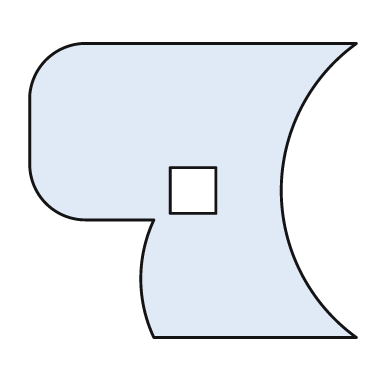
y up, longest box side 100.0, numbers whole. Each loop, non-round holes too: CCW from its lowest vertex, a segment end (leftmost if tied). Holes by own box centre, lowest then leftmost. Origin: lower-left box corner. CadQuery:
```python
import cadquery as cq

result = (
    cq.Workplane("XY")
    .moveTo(38.0, 0.0)
    .lineTo(100.0, 0.0)
    .threePointArc((77.0, 45.0), (100.0, 90.0))
    .lineTo(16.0, 90.0)
    .threePointArc((5.0, 85.0), (0.0, 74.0))
    .lineTo(0.0, 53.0)
    .threePointArc((5.0, 41.0), (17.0, 36.0))
    .lineTo(38.0, 36.0)
    .threePointArc((34.0, 18.0), (38.0, 0.0))
    .close()
    .moveTo(43.0, 38.0)
    .lineTo(57.0, 38.0)
    .lineTo(57.0, 52.0)
    .lineTo(43.0, 52.0)
    .close()
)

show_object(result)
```